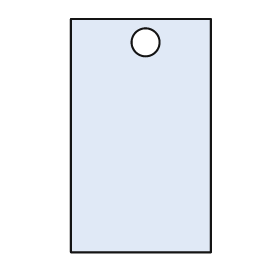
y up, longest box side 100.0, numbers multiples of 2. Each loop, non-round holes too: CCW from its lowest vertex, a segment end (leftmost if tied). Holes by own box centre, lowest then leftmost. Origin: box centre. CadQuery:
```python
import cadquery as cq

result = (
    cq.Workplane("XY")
    .moveTo(-30.0, -50.0)
    .lineTo(30.0, -50.0)
    .lineTo(30.0, 50.0)
    .lineTo(-30.0, 50.0)
    .close()
    .moveTo(2.0, 40.0)
    .circle(6.0)
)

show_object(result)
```